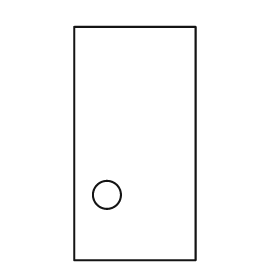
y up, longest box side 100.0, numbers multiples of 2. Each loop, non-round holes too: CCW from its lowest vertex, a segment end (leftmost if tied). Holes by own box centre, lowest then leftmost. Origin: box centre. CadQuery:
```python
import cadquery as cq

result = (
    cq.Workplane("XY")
    .moveTo(-26.0, -50.0)
    .lineTo(26.0, -50.0)
    .lineTo(26.0, 50.0)
    .lineTo(-26.0, 50.0)
    .close()
    .moveTo(-12.0, -22.0)
    .circle(6.0)
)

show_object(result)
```